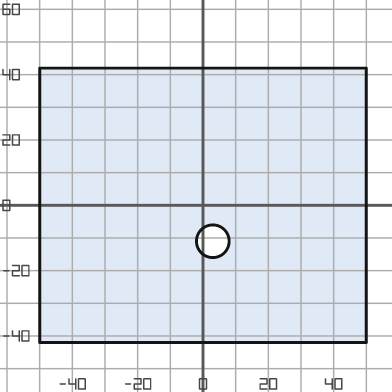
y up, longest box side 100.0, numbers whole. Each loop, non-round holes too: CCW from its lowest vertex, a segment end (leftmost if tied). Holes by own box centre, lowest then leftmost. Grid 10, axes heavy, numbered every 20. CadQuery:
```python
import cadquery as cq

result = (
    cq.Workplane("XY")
    .moveTo(-50.0, -42.0)
    .lineTo(50.0, -42.0)
    .lineTo(50.0, 42.0)
    .lineTo(-50.0, 42.0)
    .close()
    .moveTo(3.0, -11.0)
    .circle(5.0)
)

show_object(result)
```